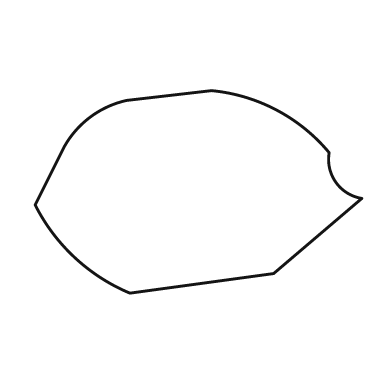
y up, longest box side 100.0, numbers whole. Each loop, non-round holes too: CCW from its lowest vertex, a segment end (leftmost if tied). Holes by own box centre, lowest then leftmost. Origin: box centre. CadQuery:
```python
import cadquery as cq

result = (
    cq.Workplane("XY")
    .moveTo(-21.0, -31.0)
    .lineTo(23.0, -25.0)
    .lineTo(50.0, -2.0)
    .threePointArc((42.0, 3.0), (40.0, 12.0))
    .threePointArc((24.0, 25.0), (4.0, 31.0))
    .lineTo(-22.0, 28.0)
    .threePointArc((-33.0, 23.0), (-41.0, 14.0))
    .lineTo(-50.0, -4.0)
    .threePointArc((-38.0, -20.0), (-21.0, -31.0))
    .close()
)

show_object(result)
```